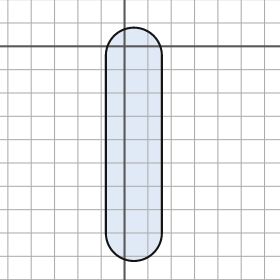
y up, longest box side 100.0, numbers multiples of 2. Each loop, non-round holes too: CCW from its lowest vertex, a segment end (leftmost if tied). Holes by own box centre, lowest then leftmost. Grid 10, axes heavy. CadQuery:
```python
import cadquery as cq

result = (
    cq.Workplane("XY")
    .moveTo(-8.0, -80.0)
    .threePointArc((4.0, -92.0), (16.0, -80.0))
    .lineTo(16.0, -4.0)
    .threePointArc((4.0, 8.0), (-8.0, -4.0))
    .close()
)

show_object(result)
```